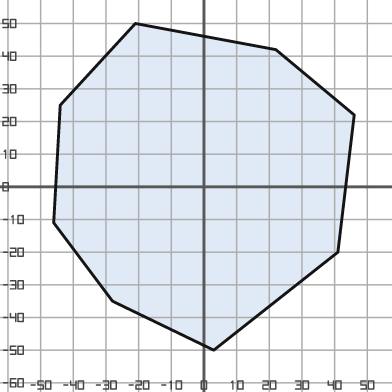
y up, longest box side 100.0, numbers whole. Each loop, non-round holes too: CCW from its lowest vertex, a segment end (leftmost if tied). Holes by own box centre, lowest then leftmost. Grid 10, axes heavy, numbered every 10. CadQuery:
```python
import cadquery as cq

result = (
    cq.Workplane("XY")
    .moveTo(3.0, -50.0)
    .lineTo(41.0, -20.0)
    .lineTo(46.0, 22.0)
    .lineTo(22.0, 42.0)
    .lineTo(-21.0, 50.0)
    .lineTo(-44.0, 25.0)
    .lineTo(-46.0, -11.0)
    .lineTo(-28.0, -35.0)
    .close()
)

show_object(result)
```